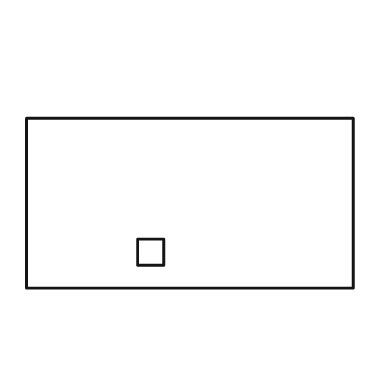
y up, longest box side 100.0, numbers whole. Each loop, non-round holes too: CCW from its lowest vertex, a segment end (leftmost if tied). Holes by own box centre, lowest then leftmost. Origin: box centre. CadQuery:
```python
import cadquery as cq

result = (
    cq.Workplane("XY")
    .moveTo(-50.0, -26.0)
    .lineTo(50.0, -26.0)
    .lineTo(50.0, 26.0)
    .lineTo(-50.0, 26.0)
    .close()
    .moveTo(-16.0, -19.0)
    .lineTo(-8.0, -19.0)
    .lineTo(-8.0, -11.0)
    .lineTo(-16.0, -11.0)
    .close()
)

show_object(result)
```